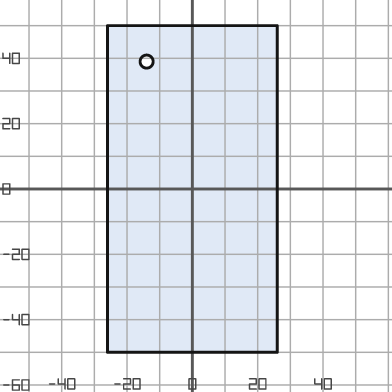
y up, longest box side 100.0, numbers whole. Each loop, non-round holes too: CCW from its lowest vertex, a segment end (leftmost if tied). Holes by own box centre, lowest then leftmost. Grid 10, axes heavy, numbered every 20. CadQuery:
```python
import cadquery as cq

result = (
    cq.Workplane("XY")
    .moveTo(-26.0, -50.0)
    .lineTo(26.0, -50.0)
    .lineTo(26.0, 50.0)
    .lineTo(-26.0, 50.0)
    .close()
    .moveTo(-14.0, 39.0)
    .circle(2.0)
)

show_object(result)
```